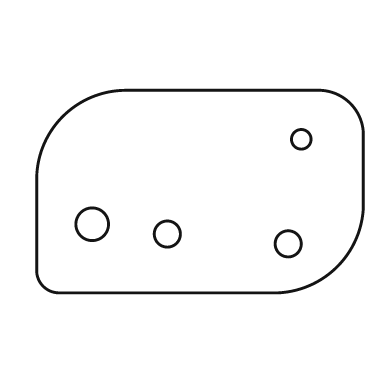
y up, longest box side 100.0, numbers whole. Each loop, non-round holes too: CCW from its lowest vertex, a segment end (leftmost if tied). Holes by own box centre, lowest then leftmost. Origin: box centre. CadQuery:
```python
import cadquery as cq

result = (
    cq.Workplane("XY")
    .moveTo(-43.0, -31.0)
    .lineTo(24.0, -31.0)
    .threePointArc((42.0, -23.0), (50.0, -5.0))
    .lineTo(50.0, 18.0)
    .threePointArc((46.0, 27.0), (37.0, 31.0))
    .lineTo(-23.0, 31.0)
    .threePointArc((-42.0, 23.0), (-50.0, 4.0))
    .lineTo(-50.0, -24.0)
    .threePointArc((-48.0, -29.0), (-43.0, -31.0))
    .close()
    .moveTo(27.0, -16.0)
    .circle(4.0)
    .moveTo(-10.0, -13.0)
    .circle(4.0)
    .moveTo(-33.0, -10.0)
    .circle(5.0)
    .moveTo(31.0, 16.0)
    .circle(3.0)
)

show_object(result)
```